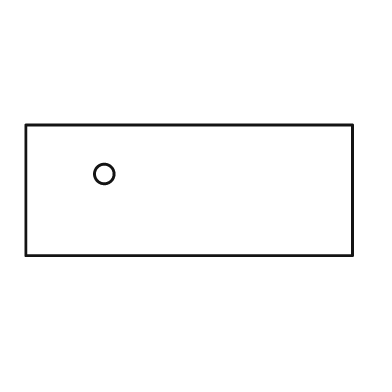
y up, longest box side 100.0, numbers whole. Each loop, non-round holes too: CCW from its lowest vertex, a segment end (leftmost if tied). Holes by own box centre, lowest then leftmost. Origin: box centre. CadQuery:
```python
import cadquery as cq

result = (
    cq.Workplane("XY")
    .moveTo(-50.0, -20.0)
    .lineTo(50.0, -20.0)
    .lineTo(50.0, 20.0)
    .lineTo(-50.0, 20.0)
    .close()
    .moveTo(-26.0, 5.0)
    .circle(3.0)
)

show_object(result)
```